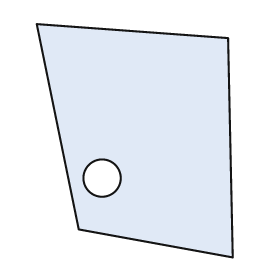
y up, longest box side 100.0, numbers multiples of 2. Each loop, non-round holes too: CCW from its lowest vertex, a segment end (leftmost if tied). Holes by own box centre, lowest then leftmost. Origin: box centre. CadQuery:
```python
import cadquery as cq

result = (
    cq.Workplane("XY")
    .moveTo(42.0, -50.0)
    .lineTo(40.0, 44.0)
    .lineTo(-42.0, 50.0)
    .lineTo(-24.0, -38.0)
    .close()
    .moveTo(-14.0, -16.0)
    .circle(8.0)
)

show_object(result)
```